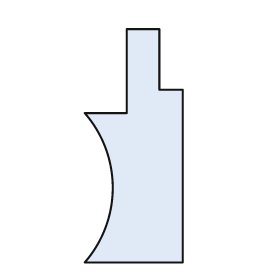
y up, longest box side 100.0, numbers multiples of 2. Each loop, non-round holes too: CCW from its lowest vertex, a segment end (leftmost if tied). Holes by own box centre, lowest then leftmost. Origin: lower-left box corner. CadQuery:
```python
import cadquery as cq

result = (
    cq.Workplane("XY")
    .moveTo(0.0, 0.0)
    .lineTo(42.0, 0.0)
    .lineTo(42.0, 74.0)
    .lineTo(32.0, 74.0)
    .lineTo(32.0, 100.0)
    .lineTo(18.0, 100.0)
    .lineTo(18.0, 64.0)
    .lineTo(0.0, 64.0)
    .threePointArc((12.0, 32.0), (0.0, 0.0))
    .close()
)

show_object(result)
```